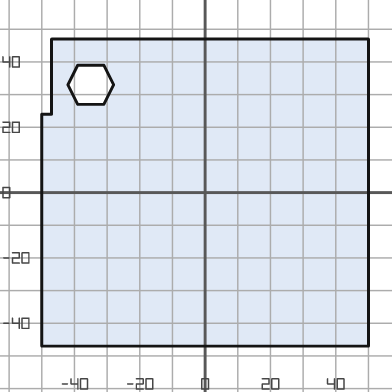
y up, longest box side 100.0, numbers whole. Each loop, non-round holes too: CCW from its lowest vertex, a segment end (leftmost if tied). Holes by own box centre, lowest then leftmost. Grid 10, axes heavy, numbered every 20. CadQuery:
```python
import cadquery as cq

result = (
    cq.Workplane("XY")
    .moveTo(-50.0, -47.0)
    .lineTo(50.0, -47.0)
    .lineTo(50.0, 47.0)
    .lineTo(-47.0, 47.0)
    .lineTo(-47.0, 24.0)
    .lineTo(-50.0, 24.0)
    .close()
    .moveTo(-39.0, 27.0)
    .lineTo(-31.0, 27.0)
    .lineTo(-28.0, 33.0)
    .lineTo(-31.0, 39.0)
    .lineTo(-39.0, 39.0)
    .lineTo(-42.0, 33.0)
    .close()
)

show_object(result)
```